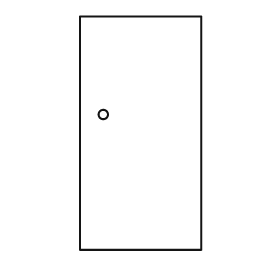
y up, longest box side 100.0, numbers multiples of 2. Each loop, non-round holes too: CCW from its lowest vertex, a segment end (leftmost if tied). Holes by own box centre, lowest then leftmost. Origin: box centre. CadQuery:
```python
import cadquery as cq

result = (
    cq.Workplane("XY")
    .moveTo(-26.0, -50.0)
    .lineTo(26.0, -50.0)
    .lineTo(26.0, 50.0)
    .lineTo(-26.0, 50.0)
    .close()
    .moveTo(-16.0, 8.0)
    .circle(2.0)
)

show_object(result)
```